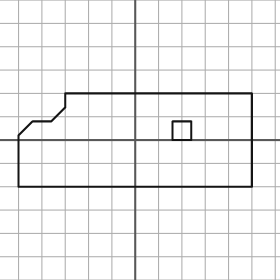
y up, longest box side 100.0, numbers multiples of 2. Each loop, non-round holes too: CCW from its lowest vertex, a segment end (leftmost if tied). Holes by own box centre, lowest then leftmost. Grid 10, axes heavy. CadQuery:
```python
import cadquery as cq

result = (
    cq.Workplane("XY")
    .moveTo(-50.0, -20.0)
    .lineTo(50.0, -20.0)
    .lineTo(50.0, 20.0)
    .lineTo(-30.0, 20.0)
    .lineTo(-30.0, 14.0)
    .lineTo(-36.0, 8.0)
    .lineTo(-44.0, 8.0)
    .lineTo(-50.0, 2.0)
    .close()
    .moveTo(16.0, 0.0)
    .lineTo(24.0, 0.0)
    .lineTo(24.0, 8.0)
    .lineTo(16.0, 8.0)
    .close()
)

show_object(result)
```